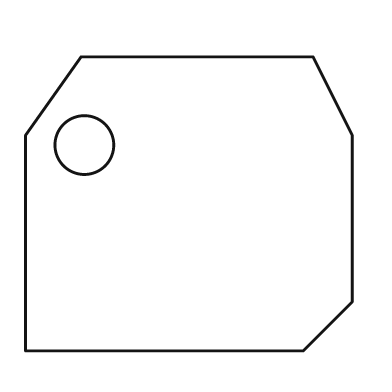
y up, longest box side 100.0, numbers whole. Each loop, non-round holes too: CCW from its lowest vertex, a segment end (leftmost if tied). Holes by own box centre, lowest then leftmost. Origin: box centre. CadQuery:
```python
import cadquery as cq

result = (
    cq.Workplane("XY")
    .moveTo(-50.0, -45.0)
    .lineTo(35.0, -45.0)
    .lineTo(50.0, -30.0)
    .lineTo(50.0, 21.0)
    .lineTo(38.0, 45.0)
    .lineTo(-33.0, 45.0)
    .lineTo(-50.0, 21.0)
    .close()
    .moveTo(-32.0, 18.0)
    .circle(9.0)
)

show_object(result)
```